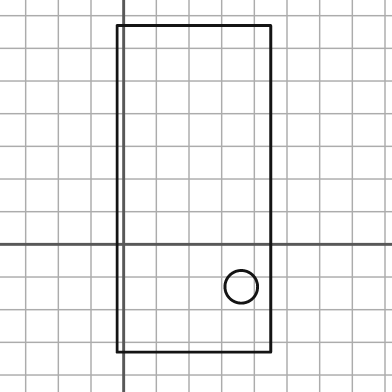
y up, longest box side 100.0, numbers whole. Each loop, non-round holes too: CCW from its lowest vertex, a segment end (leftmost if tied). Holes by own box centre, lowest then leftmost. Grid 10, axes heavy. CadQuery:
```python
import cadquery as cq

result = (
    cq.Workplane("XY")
    .moveTo(-2.0, -33.0)
    .lineTo(45.0, -33.0)
    .lineTo(45.0, 67.0)
    .lineTo(-2.0, 67.0)
    .close()
    .moveTo(36.0, -13.0)
    .circle(5.0)
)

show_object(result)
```